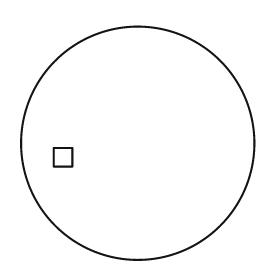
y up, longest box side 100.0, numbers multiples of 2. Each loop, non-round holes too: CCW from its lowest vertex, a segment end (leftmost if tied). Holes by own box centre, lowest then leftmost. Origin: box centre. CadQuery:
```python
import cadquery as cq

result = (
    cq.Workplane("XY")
    .moveTo(0.0, 0.0)
    .circle(50.0)
    .moveTo(-36.0, -10.0)
    .lineTo(-28.0, -10.0)
    .lineTo(-28.0, -2.0)
    .lineTo(-36.0, -2.0)
    .close()
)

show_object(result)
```